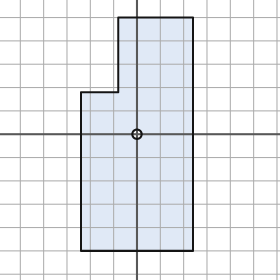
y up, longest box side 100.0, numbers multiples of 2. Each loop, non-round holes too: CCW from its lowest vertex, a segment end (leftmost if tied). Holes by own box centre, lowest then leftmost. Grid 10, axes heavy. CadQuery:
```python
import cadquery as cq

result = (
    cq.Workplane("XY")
    .moveTo(-24.0, -50.0)
    .lineTo(24.0, -50.0)
    .lineTo(24.0, 50.0)
    .lineTo(-8.0, 50.0)
    .lineTo(-8.0, 18.0)
    .lineTo(-24.0, 18.0)
    .close()
    .moveTo(0.0, 0.0)
    .circle(2.0)
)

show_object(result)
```